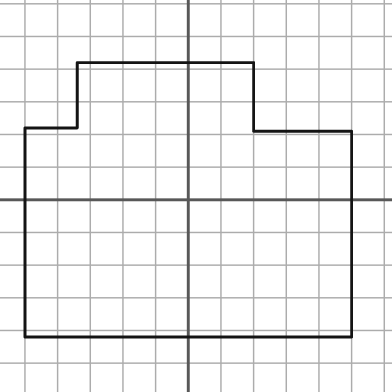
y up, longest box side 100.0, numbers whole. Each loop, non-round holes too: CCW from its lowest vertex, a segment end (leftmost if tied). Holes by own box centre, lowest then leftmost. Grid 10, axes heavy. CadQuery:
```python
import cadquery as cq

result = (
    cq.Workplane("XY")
    .moveTo(-50.0, -42.0)
    .lineTo(50.0, -42.0)
    .lineTo(50.0, 21.0)
    .lineTo(20.0, 21.0)
    .lineTo(20.0, 42.0)
    .lineTo(-34.0, 42.0)
    .lineTo(-34.0, 22.0)
    .lineTo(-50.0, 22.0)
    .close()
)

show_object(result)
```